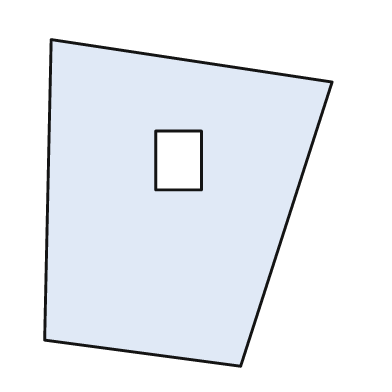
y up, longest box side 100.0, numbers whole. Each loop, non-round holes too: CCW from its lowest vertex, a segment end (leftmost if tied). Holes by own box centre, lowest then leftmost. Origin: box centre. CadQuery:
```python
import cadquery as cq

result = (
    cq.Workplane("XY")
    .moveTo(16.0, -50.0)
    .lineTo(44.0, 37.0)
    .lineTo(-42.0, 50.0)
    .lineTo(-44.0, -42.0)
    .close()
    .moveTo(-10.0, 4.0)
    .lineTo(4.0, 4.0)
    .lineTo(4.0, 22.0)
    .lineTo(-10.0, 22.0)
    .close()
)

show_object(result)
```